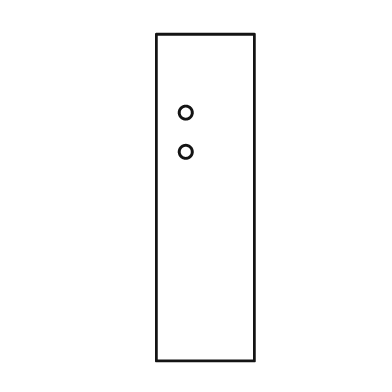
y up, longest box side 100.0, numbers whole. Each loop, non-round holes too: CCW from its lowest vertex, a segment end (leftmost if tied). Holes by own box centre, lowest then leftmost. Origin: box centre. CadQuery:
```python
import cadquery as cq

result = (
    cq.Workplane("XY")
    .moveTo(-15.0, -50.0)
    .lineTo(15.0, -50.0)
    .lineTo(15.0, 50.0)
    .lineTo(-15.0, 50.0)
    .close()
    .moveTo(-6.0, 14.0)
    .circle(2.0)
    .moveTo(-6.0, 26.0)
    .circle(2.0)
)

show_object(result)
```